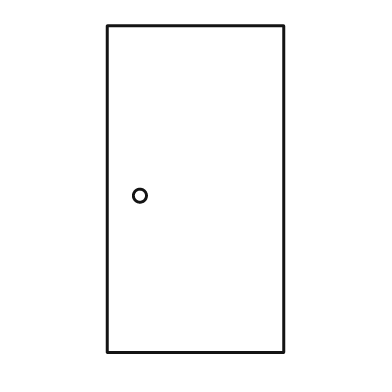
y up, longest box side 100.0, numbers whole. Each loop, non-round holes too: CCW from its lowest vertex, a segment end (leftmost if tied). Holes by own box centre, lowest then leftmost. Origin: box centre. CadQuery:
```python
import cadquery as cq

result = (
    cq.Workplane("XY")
    .moveTo(-27.0, -50.0)
    .lineTo(27.0, -50.0)
    .lineTo(27.0, 50.0)
    .lineTo(-27.0, 50.0)
    .close()
    .moveTo(-17.0, -2.0)
    .circle(2.0)
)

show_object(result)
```